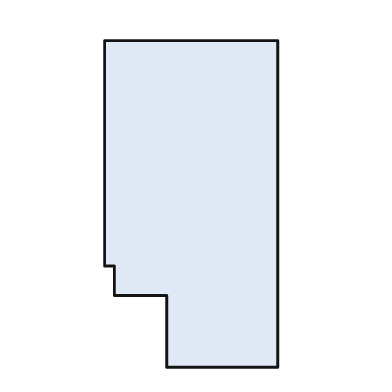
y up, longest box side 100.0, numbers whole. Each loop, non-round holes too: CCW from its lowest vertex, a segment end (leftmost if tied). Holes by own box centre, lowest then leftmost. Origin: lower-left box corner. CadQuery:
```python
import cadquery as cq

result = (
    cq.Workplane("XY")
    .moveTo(19.0, 0.0)
    .lineTo(53.0, 0.0)
    .lineTo(53.0, 100.0)
    .lineTo(0.0, 100.0)
    .lineTo(0.0, 31.0)
    .lineTo(3.0, 31.0)
    .lineTo(3.0, 22.0)
    .lineTo(19.0, 22.0)
    .close()
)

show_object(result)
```